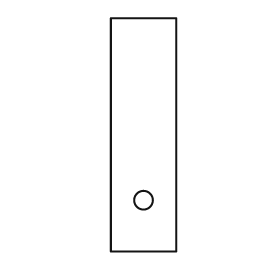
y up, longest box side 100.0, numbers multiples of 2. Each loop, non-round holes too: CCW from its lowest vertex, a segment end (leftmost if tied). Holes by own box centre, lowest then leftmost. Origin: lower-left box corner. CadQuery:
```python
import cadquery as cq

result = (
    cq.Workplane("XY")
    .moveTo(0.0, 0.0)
    .lineTo(28.0, 0.0)
    .lineTo(28.0, 100.0)
    .lineTo(0.0, 100.0)
    .close()
    .moveTo(14.0, 22.0)
    .circle(4.0)
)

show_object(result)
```